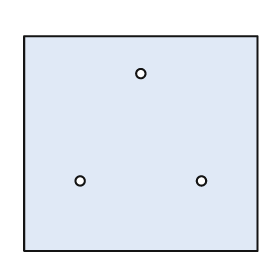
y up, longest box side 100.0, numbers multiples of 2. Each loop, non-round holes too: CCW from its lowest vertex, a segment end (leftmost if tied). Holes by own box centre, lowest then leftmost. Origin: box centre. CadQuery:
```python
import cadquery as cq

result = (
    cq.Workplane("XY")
    .moveTo(-50.0, -46.0)
    .lineTo(50.0, -46.0)
    .lineTo(50.0, 46.0)
    .lineTo(-50.0, 46.0)
    .close()
    .moveTo(-26.0, -16.0)
    .circle(2.0)
    .moveTo(26.0, -16.0)
    .circle(2.0)
    .moveTo(0.0, 30.0)
    .circle(2.0)
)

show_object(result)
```